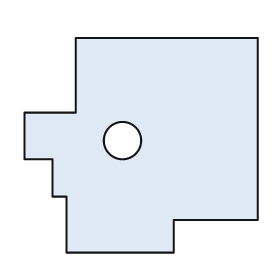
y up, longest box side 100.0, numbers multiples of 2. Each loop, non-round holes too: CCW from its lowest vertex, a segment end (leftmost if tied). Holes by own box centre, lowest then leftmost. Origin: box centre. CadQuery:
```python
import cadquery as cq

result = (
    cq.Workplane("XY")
    .moveTo(-32.0, -46.0)
    .lineTo(14.0, -46.0)
    .lineTo(14.0, -32.0)
    .lineTo(50.0, -32.0)
    .lineTo(50.0, 46.0)
    .lineTo(-28.0, 46.0)
    .lineTo(-28.0, 14.0)
    .lineTo(-50.0, 14.0)
    .lineTo(-50.0, -6.0)
    .lineTo(-38.0, -6.0)
    .lineTo(-38.0, -22.0)
    .lineTo(-32.0, -22.0)
    .close()
    .moveTo(-8.0, 2.0)
    .circle(8.0)
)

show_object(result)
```